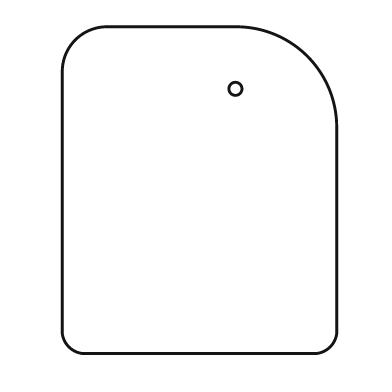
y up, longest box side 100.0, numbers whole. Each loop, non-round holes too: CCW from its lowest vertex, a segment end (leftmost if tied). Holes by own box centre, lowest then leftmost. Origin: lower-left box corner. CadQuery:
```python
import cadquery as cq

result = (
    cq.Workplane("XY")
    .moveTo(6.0, 0.0)
    .lineTo(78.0, 0.0)
    .threePointArc((82.0, 2.0), (84.0, 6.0))
    .lineTo(84.0, 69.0)
    .threePointArc((75.0, 91.0), (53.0, 100.0))
    .lineTo(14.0, 100.0)
    .threePointArc((4.0, 96.0), (0.0, 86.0))
    .lineTo(0.0, 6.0)
    .threePointArc((2.0, 2.0), (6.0, 0.0))
    .close()
    .moveTo(53.0, 81.0)
    .circle(2.0)
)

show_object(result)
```